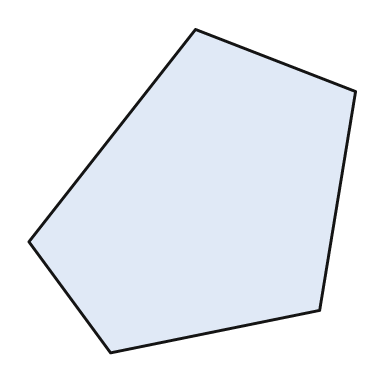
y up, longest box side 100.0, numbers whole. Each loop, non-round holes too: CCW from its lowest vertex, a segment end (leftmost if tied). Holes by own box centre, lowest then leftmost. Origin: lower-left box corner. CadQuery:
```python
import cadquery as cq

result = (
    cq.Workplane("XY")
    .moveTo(25.0, 0.0)
    .lineTo(89.0, 13.0)
    .lineTo(100.0, 80.0)
    .lineTo(51.0, 99.0)
    .lineTo(0.0, 34.0)
    .close()
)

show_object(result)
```